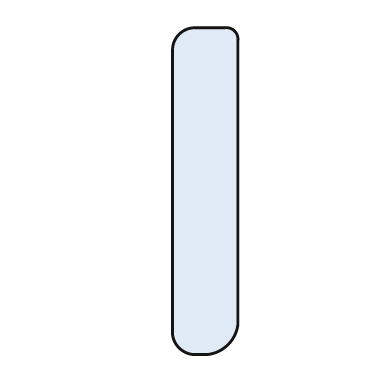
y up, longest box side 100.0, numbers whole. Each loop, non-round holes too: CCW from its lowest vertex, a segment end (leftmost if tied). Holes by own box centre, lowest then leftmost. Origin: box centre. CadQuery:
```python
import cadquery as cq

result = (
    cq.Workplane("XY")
    .moveTo(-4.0, -50.0)
    .lineTo(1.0, -50.0)
    .threePointArc((7.0, -47.0), (10.0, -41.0))
    .lineTo(10.0, 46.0)
    .threePointArc((9.0, 49.0), (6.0, 50.0))
    .lineTo(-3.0, 50.0)
    .threePointArc((-8.0, 48.0), (-10.0, 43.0))
    .lineTo(-10.0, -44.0)
    .threePointArc((-8.0, -48.0), (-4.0, -50.0))
    .close()
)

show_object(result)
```